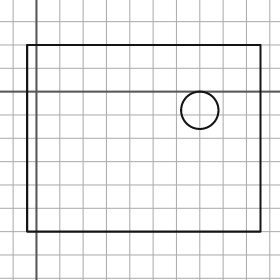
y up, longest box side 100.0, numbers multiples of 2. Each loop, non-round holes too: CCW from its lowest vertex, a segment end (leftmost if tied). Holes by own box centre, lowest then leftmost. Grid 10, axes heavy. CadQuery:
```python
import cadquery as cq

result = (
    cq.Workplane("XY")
    .moveTo(-4.0, -60.0)
    .lineTo(96.0, -60.0)
    .lineTo(96.0, 20.0)
    .lineTo(-4.0, 20.0)
    .close()
    .moveTo(70.0, -8.0)
    .circle(8.0)
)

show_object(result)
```